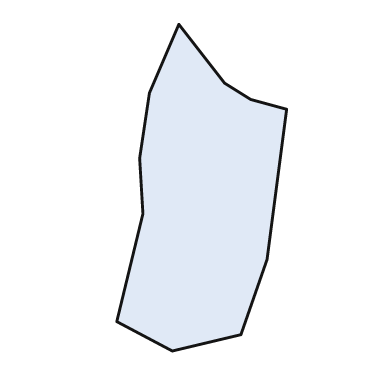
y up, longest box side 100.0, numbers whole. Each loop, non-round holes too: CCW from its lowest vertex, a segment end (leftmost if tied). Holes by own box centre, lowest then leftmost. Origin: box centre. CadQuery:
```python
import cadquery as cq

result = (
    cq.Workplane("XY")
    .moveTo(-9.0, -50.0)
    .lineTo(12.0, -45.0)
    .lineTo(20.0, -22.0)
    .lineTo(26.0, 24.0)
    .lineTo(15.0, 27.0)
    .lineTo(7.0, 32.0)
    .lineTo(-7.0, 50.0)
    .lineTo(-16.0, 29.0)
    .lineTo(-19.0, 9.0)
    .lineTo(-18.0, -8.0)
    .lineTo(-26.0, -41.0)
    .close()
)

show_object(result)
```